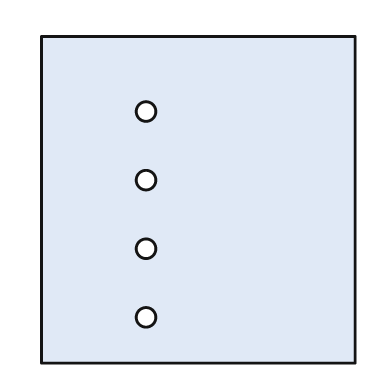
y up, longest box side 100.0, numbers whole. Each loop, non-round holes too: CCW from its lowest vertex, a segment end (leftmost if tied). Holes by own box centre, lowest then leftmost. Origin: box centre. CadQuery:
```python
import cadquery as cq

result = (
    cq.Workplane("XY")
    .moveTo(-48.0, -50.0)
    .lineTo(48.0, -50.0)
    .lineTo(48.0, 50.0)
    .lineTo(-48.0, 50.0)
    .close()
    .moveTo(-16.0, -36.0)
    .circle(3.0)
    .moveTo(-16.0, -15.0)
    .circle(3.0)
    .moveTo(-16.0, 6.0)
    .circle(3.0)
    .moveTo(-16.0, 27.0)
    .circle(3.0)
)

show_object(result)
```